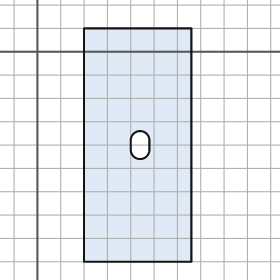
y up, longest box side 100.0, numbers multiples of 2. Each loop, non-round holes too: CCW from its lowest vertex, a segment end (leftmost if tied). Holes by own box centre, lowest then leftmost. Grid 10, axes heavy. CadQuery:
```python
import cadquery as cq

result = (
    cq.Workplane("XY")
    .moveTo(20.0, -90.0)
    .lineTo(66.0, -90.0)
    .lineTo(66.0, 10.0)
    .lineTo(20.0, 10.0)
    .close()
    .moveTo(40.0, -42.0)
    .threePointArc((44.0, -46.0), (48.0, -42.0))
    .lineTo(48.0, -38.0)
    .threePointArc((44.0, -34.0), (40.0, -38.0))
    .close()
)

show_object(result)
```